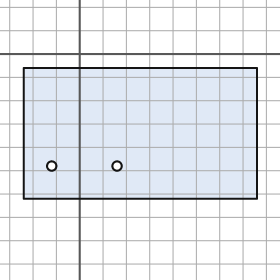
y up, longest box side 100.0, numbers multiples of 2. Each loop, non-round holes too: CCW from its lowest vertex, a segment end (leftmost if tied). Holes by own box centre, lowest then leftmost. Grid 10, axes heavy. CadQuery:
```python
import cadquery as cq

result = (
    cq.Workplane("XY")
    .moveTo(-24.0, -62.0)
    .lineTo(76.0, -62.0)
    .lineTo(76.0, -6.0)
    .lineTo(-24.0, -6.0)
    .close()
    .moveTo(-12.0, -48.0)
    .circle(2.0)
    .moveTo(16.0, -48.0)
    .circle(2.0)
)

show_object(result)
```